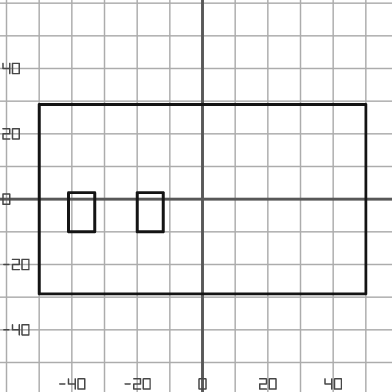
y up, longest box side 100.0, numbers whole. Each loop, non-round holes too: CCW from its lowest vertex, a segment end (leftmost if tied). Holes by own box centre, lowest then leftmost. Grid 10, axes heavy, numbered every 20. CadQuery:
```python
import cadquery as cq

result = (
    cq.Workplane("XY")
    .moveTo(-50.0, -29.0)
    .lineTo(50.0, -29.0)
    .lineTo(50.0, 29.0)
    .lineTo(-50.0, 29.0)
    .close()
    .moveTo(-41.0, -10.0)
    .lineTo(-33.0, -10.0)
    .lineTo(-33.0, 2.0)
    .lineTo(-41.0, 2.0)
    .close()
    .moveTo(-20.0, -10.0)
    .lineTo(-12.0, -10.0)
    .lineTo(-12.0, 2.0)
    .lineTo(-20.0, 2.0)
    .close()
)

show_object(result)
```